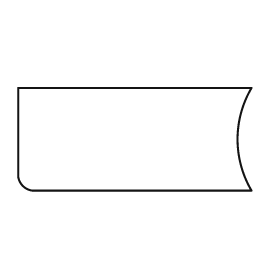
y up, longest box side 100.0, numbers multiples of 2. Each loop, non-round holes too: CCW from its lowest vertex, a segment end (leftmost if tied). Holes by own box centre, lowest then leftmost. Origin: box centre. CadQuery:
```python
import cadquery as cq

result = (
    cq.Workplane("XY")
    .moveTo(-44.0, -22.0)
    .lineTo(50.0, -22.0)
    .threePointArc((44.0, 0.0), (50.0, 22.0))
    .lineTo(-50.0, 22.0)
    .lineTo(-50.0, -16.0)
    .threePointArc((-48.0, -20.0), (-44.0, -22.0))
    .close()
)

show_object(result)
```